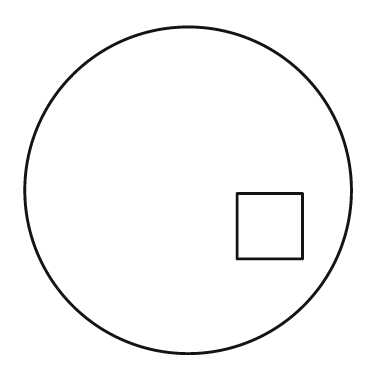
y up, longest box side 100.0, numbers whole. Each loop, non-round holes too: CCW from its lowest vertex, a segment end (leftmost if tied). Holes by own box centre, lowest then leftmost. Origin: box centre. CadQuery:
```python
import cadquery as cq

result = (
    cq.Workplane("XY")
    .moveTo(0.0, 0.0)
    .circle(50.0)
    .moveTo(15.0, -21.0)
    .lineTo(35.0, -21.0)
    .lineTo(35.0, -1.0)
    .lineTo(15.0, -1.0)
    .close()
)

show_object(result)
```